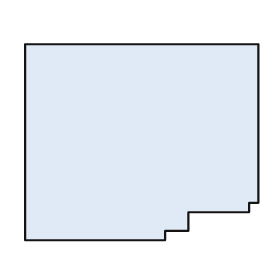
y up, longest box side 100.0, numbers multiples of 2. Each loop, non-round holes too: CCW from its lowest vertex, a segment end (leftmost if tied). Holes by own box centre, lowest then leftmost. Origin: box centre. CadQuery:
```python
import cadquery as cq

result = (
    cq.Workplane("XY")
    .moveTo(-50.0, -42.0)
    .lineTo(10.0, -42.0)
    .lineTo(10.0, -38.0)
    .lineTo(20.0, -38.0)
    .lineTo(20.0, -30.0)
    .lineTo(46.0, -30.0)
    .lineTo(46.0, -26.0)
    .lineTo(50.0, -26.0)
    .lineTo(50.0, 42.0)
    .lineTo(-50.0, 42.0)
    .close()
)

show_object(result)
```